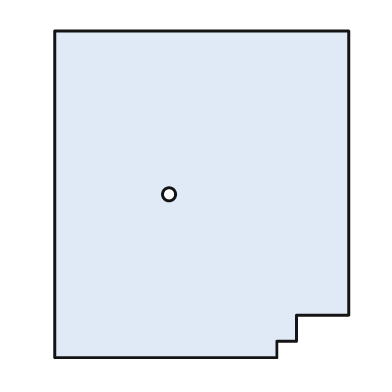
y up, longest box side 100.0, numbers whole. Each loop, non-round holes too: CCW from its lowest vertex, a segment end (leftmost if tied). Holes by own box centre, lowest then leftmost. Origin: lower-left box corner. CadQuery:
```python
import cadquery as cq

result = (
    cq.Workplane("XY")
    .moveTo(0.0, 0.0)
    .lineTo(68.0, 0.0)
    .lineTo(68.0, 5.0)
    .lineTo(74.0, 5.0)
    .lineTo(74.0, 13.0)
    .lineTo(90.0, 13.0)
    .lineTo(90.0, 100.0)
    .lineTo(0.0, 100.0)
    .close()
    .moveTo(35.0, 50.0)
    .circle(2.0)
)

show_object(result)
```